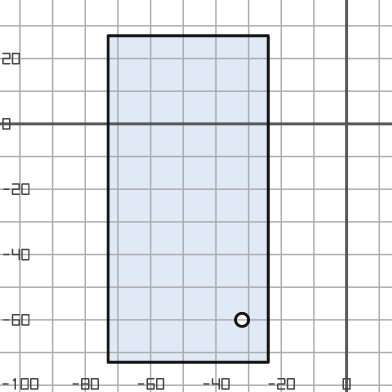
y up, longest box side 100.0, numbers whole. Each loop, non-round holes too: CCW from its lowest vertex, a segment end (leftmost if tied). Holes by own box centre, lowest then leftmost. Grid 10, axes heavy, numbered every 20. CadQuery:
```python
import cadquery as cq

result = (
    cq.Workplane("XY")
    .moveTo(-73.0, -73.0)
    .lineTo(-24.0, -73.0)
    .lineTo(-24.0, 27.0)
    .lineTo(-73.0, 27.0)
    .close()
    .moveTo(-32.0, -60.0)
    .circle(2.0)
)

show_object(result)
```